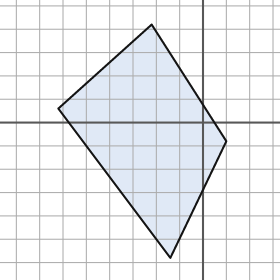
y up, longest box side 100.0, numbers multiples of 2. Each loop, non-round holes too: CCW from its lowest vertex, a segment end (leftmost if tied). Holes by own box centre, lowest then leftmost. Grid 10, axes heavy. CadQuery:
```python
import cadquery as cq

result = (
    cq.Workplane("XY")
    .moveTo(-14.0, -58.0)
    .lineTo(10.0, -8.0)
    .lineTo(-22.0, 42.0)
    .lineTo(-62.0, 6.0)
    .close()
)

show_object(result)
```